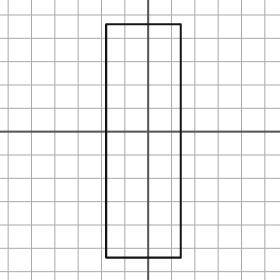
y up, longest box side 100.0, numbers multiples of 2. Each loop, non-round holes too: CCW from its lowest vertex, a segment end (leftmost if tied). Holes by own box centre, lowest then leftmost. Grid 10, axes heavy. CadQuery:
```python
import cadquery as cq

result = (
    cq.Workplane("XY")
    .moveTo(-18.0, -54.0)
    .lineTo(14.0, -54.0)
    .lineTo(14.0, 46.0)
    .lineTo(-18.0, 46.0)
    .close()
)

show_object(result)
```